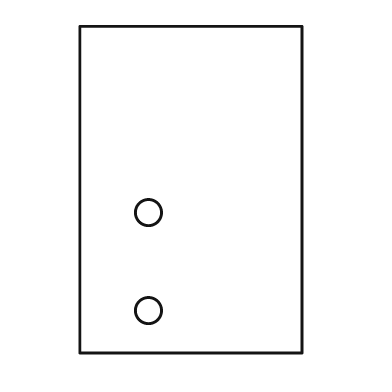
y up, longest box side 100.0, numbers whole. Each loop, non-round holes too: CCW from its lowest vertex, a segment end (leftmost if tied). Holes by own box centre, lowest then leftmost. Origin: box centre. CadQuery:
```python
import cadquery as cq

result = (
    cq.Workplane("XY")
    .moveTo(-34.0, -50.0)
    .lineTo(34.0, -50.0)
    .lineTo(34.0, 50.0)
    .lineTo(-34.0, 50.0)
    .close()
    .moveTo(-13.0, -37.0)
    .circle(4.0)
    .moveTo(-13.0, -7.0)
    .circle(4.0)
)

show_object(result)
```